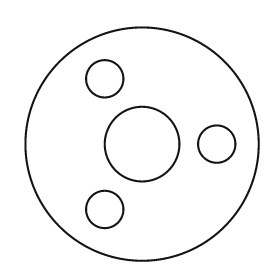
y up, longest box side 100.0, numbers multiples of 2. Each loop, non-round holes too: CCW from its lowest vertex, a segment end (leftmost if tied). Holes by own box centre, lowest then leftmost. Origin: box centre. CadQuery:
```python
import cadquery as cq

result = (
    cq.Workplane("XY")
    .moveTo(0.0, 0.0)
    .circle(50.0)
    .moveTo(-16.0, -28.0)
    .circle(8.0)
    .moveTo(0.0, 0.0)
    .circle(16.0)
    .moveTo(32.0, 0.0)
    .circle(8.0)
    .moveTo(-16.0, 28.0)
    .circle(8.0)
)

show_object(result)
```